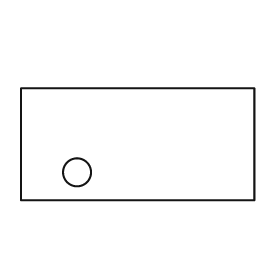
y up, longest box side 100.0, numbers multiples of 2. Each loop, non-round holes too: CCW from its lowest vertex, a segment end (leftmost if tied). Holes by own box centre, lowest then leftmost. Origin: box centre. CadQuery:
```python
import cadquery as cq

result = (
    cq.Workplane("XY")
    .moveTo(-50.0, -24.0)
    .lineTo(50.0, -24.0)
    .lineTo(50.0, 24.0)
    .lineTo(-50.0, 24.0)
    .close()
    .moveTo(-26.0, -12.0)
    .circle(6.0)
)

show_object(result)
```